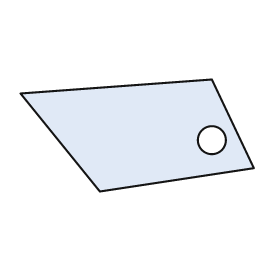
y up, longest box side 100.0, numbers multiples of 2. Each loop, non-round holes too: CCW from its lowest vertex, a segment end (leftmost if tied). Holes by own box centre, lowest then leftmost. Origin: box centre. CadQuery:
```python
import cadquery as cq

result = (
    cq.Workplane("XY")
    .moveTo(-16.0, -24.0)
    .lineTo(50.0, -14.0)
    .lineTo(32.0, 24.0)
    .lineTo(-50.0, 18.0)
    .close()
    .moveTo(32.0, -2.0)
    .circle(6.0)
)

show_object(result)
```